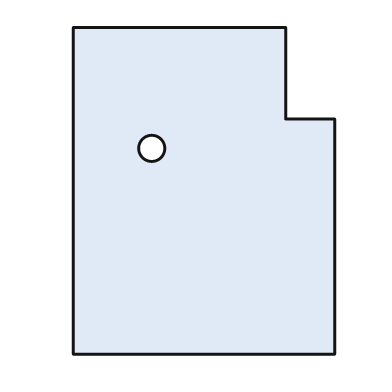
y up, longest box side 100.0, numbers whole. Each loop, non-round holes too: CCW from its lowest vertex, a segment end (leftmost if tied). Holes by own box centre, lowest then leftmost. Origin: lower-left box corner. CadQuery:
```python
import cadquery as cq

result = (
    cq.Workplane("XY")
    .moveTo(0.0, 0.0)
    .lineTo(80.0, 0.0)
    .lineTo(80.0, 72.0)
    .lineTo(65.0, 72.0)
    .lineTo(65.0, 100.0)
    .lineTo(0.0, 100.0)
    .close()
    .moveTo(24.0, 63.0)
    .circle(4.0)
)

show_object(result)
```